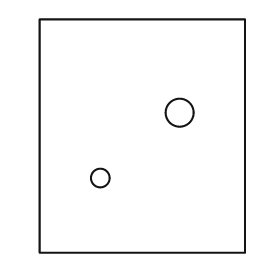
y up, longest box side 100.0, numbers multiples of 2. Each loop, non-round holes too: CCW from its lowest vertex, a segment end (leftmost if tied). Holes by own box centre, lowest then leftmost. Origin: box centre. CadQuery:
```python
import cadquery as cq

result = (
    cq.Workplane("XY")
    .moveTo(-44.0, -50.0)
    .lineTo(44.0, -50.0)
    .lineTo(44.0, 50.0)
    .lineTo(-44.0, 50.0)
    .close()
    .moveTo(-18.0, -18.0)
    .circle(4.0)
    .moveTo(16.0, 10.0)
    .circle(6.0)
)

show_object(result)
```